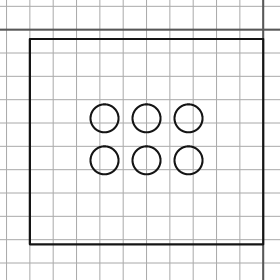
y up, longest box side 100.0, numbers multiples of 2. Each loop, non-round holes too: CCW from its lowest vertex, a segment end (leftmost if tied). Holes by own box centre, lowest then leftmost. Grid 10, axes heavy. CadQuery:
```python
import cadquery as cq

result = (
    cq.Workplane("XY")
    .moveTo(-100.0, -92.0)
    .lineTo(0.0, -92.0)
    .lineTo(0.0, -4.0)
    .lineTo(-100.0, -4.0)
    .close()
    .moveTo(-68.0, -56.0)
    .circle(6.0)
    .moveTo(-50.0, -56.0)
    .circle(6.0)
    .moveTo(-32.0, -56.0)
    .circle(6.0)
    .moveTo(-68.0, -38.0)
    .circle(6.0)
    .moveTo(-50.0, -38.0)
    .circle(6.0)
    .moveTo(-32.0, -38.0)
    .circle(6.0)
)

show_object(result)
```